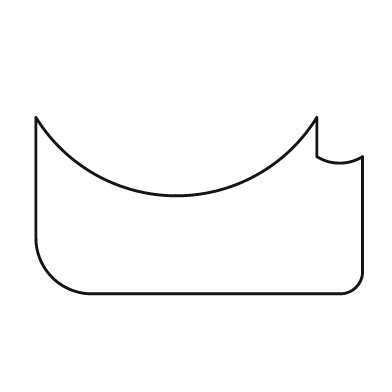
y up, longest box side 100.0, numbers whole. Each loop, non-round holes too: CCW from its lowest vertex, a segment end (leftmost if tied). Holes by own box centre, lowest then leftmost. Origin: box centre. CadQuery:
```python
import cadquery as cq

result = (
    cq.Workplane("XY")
    .moveTo(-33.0, -27.0)
    .lineTo(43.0, -27.0)
    .threePointArc((48.0, -25.0), (50.0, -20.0))
    .lineTo(50.0, 15.0)
    .threePointArc((43.0, 13.0), (36.0, 15.0))
    .lineTo(36.0, 27.0)
    .threePointArc((-7.0, 3.0), (-50.0, 27.0))
    .lineTo(-50.0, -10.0)
    .threePointArc((-45.0, -22.0), (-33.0, -27.0))
    .close()
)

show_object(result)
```